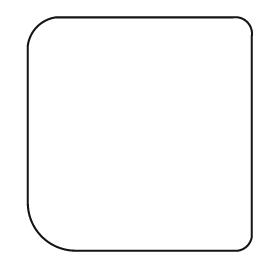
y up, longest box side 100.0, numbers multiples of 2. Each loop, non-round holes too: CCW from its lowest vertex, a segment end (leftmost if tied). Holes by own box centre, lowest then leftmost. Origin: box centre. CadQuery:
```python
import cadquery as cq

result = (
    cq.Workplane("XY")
    .moveTo(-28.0, -50.0)
    .lineTo(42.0, -50.0)
    .threePointArc((46.0, -48.0), (48.0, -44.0))
    .lineTo(48.0, 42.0)
    .threePointArc((46.0, 48.0), (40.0, 50.0))
    .lineTo(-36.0, 50.0)
    .threePointArc((-44.0, 46.0), (-48.0, 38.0))
    .lineTo(-48.0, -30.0)
    .threePointArc((-42.0, -44.0), (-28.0, -50.0))
    .close()
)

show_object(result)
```